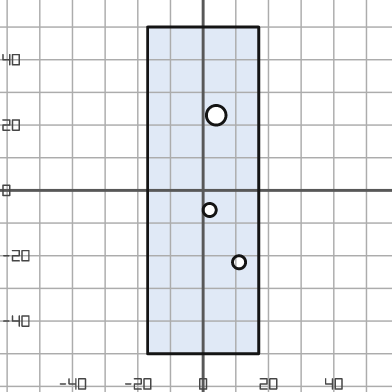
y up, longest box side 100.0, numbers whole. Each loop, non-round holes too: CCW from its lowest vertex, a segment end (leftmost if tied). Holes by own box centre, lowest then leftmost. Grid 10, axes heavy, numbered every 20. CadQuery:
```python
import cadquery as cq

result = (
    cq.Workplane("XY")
    .moveTo(-17.0, -50.0)
    .lineTo(17.0, -50.0)
    .lineTo(17.0, 50.0)
    .lineTo(-17.0, 50.0)
    .close()
    .moveTo(11.0, -22.0)
    .circle(2.0)
    .moveTo(2.0, -6.0)
    .circle(2.0)
    .moveTo(4.0, 23.0)
    .circle(3.0)
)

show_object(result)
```